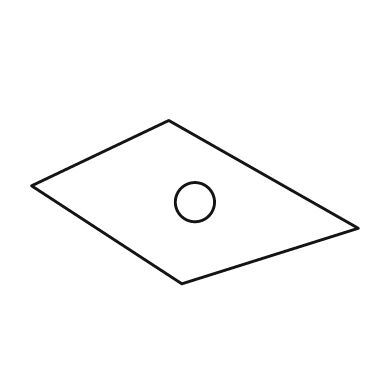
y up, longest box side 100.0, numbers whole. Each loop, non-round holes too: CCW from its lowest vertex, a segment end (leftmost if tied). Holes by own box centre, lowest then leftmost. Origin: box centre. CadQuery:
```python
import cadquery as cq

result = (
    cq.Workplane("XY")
    .moveTo(-4.0, -25.0)
    .lineTo(50.0, -8.0)
    .lineTo(-8.0, 25.0)
    .lineTo(-50.0, 5.0)
    .close()
    .moveTo(0.0, 0.0)
    .circle(6.0)
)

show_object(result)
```